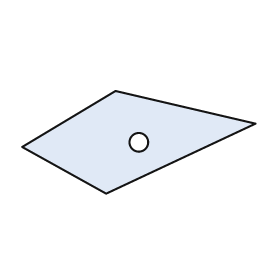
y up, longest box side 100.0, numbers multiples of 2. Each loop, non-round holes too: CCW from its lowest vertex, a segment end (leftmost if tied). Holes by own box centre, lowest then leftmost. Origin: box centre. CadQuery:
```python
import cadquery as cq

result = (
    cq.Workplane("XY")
    .moveTo(-14.0, -22.0)
    .lineTo(50.0, 8.0)
    .lineTo(-10.0, 22.0)
    .lineTo(-50.0, -2.0)
    .close()
    .moveTo(0.0, 0.0)
    .circle(4.0)
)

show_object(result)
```